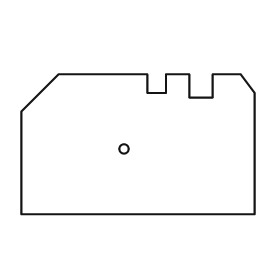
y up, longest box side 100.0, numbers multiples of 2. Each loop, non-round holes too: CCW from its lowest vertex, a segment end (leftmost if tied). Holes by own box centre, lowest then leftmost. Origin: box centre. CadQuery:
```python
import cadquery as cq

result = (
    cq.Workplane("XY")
    .moveTo(-50.0, -30.0)
    .lineTo(50.0, -30.0)
    .lineTo(50.0, 22.0)
    .lineTo(44.0, 30.0)
    .lineTo(32.0, 30.0)
    .lineTo(32.0, 20.0)
    .lineTo(22.0, 20.0)
    .lineTo(22.0, 30.0)
    .lineTo(12.0, 30.0)
    .lineTo(12.0, 22.0)
    .lineTo(4.0, 22.0)
    .lineTo(4.0, 30.0)
    .lineTo(-34.0, 30.0)
    .lineTo(-50.0, 14.0)
    .close()
    .moveTo(-6.0, -2.0)
    .circle(2.0)
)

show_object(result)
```